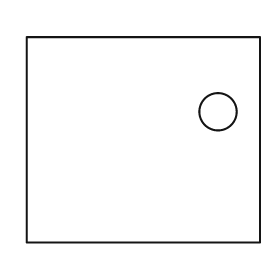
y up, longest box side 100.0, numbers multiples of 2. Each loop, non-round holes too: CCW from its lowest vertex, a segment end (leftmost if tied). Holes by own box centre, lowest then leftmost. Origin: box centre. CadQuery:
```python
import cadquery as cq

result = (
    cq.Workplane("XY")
    .moveTo(-50.0, -44.0)
    .lineTo(50.0, -44.0)
    .lineTo(50.0, 44.0)
    .lineTo(-50.0, 44.0)
    .close()
    .moveTo(32.0, 12.0)
    .circle(8.0)
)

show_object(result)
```